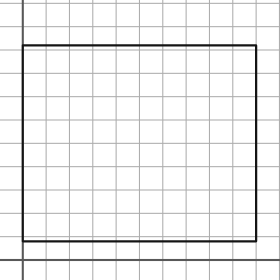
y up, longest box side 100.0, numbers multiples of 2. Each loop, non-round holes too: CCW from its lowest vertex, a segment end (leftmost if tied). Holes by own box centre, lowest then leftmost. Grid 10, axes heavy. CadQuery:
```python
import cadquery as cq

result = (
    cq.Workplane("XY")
    .moveTo(0.0, 8.0)
    .lineTo(100.0, 8.0)
    .lineTo(100.0, 92.0)
    .lineTo(0.0, 92.0)
    .close()
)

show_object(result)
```